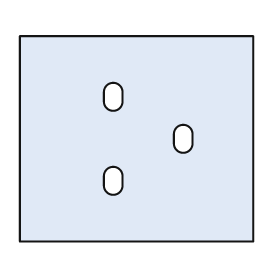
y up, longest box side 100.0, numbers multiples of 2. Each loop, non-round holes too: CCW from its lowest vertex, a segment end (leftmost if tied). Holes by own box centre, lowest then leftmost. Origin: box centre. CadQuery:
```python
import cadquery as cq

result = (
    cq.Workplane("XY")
    .moveTo(-50.0, -44.0)
    .lineTo(50.0, -44.0)
    .lineTo(50.0, 44.0)
    .lineTo(-50.0, 44.0)
    .close()
    .moveTo(-14.0, -20.0)
    .threePointArc((-10.0, -24.0), (-6.0, -20.0))
    .lineTo(-6.0, -16.0)
    .threePointArc((-10.0, -12.0), (-14.0, -16.0))
    .close()
    .moveTo(16.0, -2.0)
    .threePointArc((20.0, -6.0), (24.0, -2.0))
    .lineTo(24.0, 2.0)
    .threePointArc((20.0, 6.0), (16.0, 2.0))
    .close()
    .moveTo(-14.0, 16.0)
    .threePointArc((-10.0, 12.0), (-6.0, 16.0))
    .lineTo(-6.0, 20.0)
    .threePointArc((-10.0, 24.0), (-14.0, 20.0))
    .close()
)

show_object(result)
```